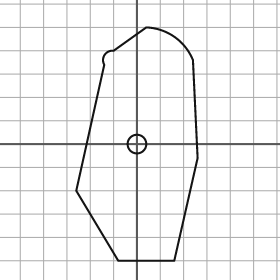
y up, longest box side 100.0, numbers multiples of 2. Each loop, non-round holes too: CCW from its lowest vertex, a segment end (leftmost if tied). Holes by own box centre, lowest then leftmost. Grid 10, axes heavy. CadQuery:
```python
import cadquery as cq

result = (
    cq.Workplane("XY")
    .moveTo(-8.0, -50.0)
    .lineTo(16.0, -50.0)
    .lineTo(26.0, -6.0)
    .lineTo(24.0, 36.0)
    .threePointArc((16.0, 46.0), (4.0, 50.0))
    .lineTo(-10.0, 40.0)
    .threePointArc((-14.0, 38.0), (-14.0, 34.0))
    .lineTo(-26.0, -20.0)
    .close()
    .moveTo(0.0, 0.0)
    .circle(4.0)
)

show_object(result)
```